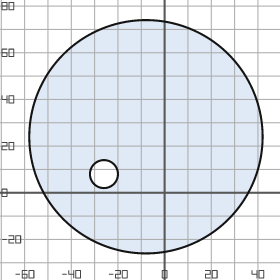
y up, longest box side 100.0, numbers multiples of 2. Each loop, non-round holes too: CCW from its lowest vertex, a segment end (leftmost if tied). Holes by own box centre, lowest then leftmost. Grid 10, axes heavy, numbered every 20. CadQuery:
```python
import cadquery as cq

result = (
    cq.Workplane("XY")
    .moveTo(-8.0, 24.0)
    .circle(50.0)
    .moveTo(-26.0, 8.0)
    .circle(6.0)
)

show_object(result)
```